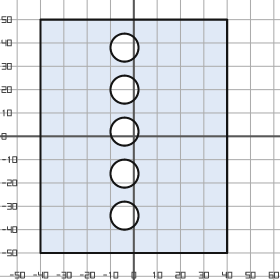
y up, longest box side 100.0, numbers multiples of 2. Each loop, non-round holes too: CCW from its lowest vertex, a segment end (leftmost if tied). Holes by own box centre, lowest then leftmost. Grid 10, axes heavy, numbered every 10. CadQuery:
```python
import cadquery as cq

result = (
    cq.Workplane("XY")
    .moveTo(-40.0, -50.0)
    .lineTo(40.0, -50.0)
    .lineTo(40.0, 50.0)
    .lineTo(-40.0, 50.0)
    .close()
    .moveTo(-4.0, -34.0)
    .circle(6.0)
    .moveTo(-4.0, -16.0)
    .circle(6.0)
    .moveTo(-4.0, 2.0)
    .circle(6.0)
    .moveTo(-4.0, 20.0)
    .circle(6.0)
    .moveTo(-4.0, 38.0)
    .circle(6.0)
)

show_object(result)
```